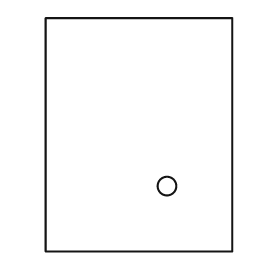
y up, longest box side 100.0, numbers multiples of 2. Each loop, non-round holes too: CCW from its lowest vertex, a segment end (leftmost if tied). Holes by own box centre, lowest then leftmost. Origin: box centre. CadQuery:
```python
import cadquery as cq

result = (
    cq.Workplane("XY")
    .moveTo(-40.0, -50.0)
    .lineTo(40.0, -50.0)
    .lineTo(40.0, 50.0)
    .lineTo(-40.0, 50.0)
    .close()
    .moveTo(12.0, -22.0)
    .circle(4.0)
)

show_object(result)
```